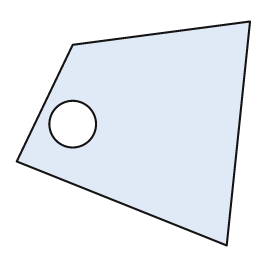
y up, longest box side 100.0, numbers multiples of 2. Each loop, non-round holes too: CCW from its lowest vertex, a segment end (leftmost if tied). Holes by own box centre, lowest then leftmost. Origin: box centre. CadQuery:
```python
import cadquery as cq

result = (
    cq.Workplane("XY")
    .moveTo(40.0, -48.0)
    .lineTo(50.0, 48.0)
    .lineTo(-26.0, 38.0)
    .lineTo(-50.0, -12.0)
    .close()
    .moveTo(-26.0, 4.0)
    .circle(10.0)
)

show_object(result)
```